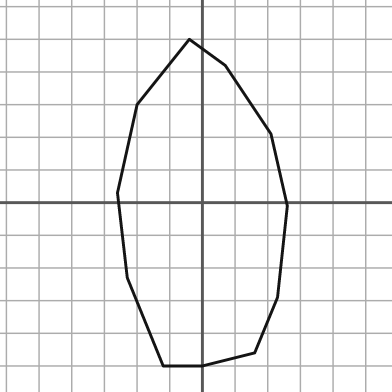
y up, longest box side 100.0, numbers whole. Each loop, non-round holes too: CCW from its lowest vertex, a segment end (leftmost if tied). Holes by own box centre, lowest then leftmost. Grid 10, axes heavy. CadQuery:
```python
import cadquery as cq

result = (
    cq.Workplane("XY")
    .moveTo(-12.0, -50.0)
    .lineTo(0.0, -50.0)
    .lineTo(16.0, -46.0)
    .lineTo(23.0, -29.0)
    .lineTo(26.0, -1.0)
    .lineTo(21.0, 21.0)
    .lineTo(7.0, 42.0)
    .lineTo(-4.0, 50.0)
    .lineTo(-20.0, 30.0)
    .lineTo(-26.0, 3.0)
    .lineTo(-23.0, -23.0)
    .close()
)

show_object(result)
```